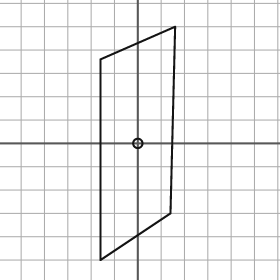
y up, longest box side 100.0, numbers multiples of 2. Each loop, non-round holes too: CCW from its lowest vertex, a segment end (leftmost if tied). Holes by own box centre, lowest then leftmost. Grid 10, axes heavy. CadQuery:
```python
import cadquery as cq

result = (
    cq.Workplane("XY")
    .moveTo(-16.0, -50.0)
    .lineTo(14.0, -30.0)
    .lineTo(16.0, 50.0)
    .lineTo(-16.0, 36.0)
    .close()
    .moveTo(0.0, 0.0)
    .circle(2.0)
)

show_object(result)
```